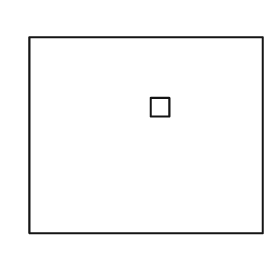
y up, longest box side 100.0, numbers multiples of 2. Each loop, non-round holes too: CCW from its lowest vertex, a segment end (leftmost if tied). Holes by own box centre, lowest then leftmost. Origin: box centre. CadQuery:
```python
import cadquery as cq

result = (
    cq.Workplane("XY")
    .moveTo(-50.0, -42.0)
    .lineTo(50.0, -42.0)
    .lineTo(50.0, 42.0)
    .lineTo(-50.0, 42.0)
    .close()
    .moveTo(2.0, 8.0)
    .lineTo(10.0, 8.0)
    .lineTo(10.0, 16.0)
    .lineTo(2.0, 16.0)
    .close()
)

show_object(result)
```